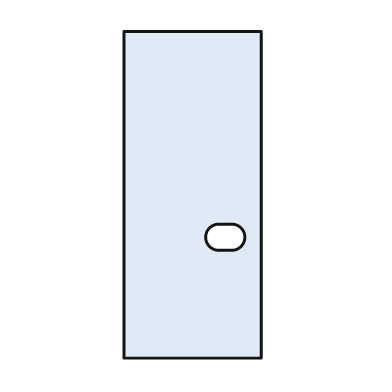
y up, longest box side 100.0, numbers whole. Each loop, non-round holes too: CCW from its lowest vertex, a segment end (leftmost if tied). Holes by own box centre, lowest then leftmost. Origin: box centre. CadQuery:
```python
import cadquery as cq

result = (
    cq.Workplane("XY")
    .moveTo(-21.0, -50.0)
    .lineTo(21.0, -50.0)
    .lineTo(21.0, 50.0)
    .lineTo(-21.0, 50.0)
    .close()
    .moveTo(8.0, -17.0)
    .lineTo(12.0, -17.0)
    .threePointArc((16.0, -13.0), (12.0, -9.0))
    .lineTo(8.0, -9.0)
    .threePointArc((4.0, -13.0), (8.0, -17.0))
    .close()
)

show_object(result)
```